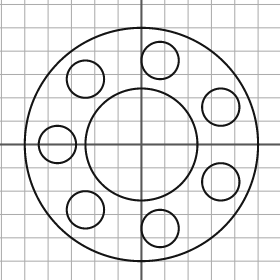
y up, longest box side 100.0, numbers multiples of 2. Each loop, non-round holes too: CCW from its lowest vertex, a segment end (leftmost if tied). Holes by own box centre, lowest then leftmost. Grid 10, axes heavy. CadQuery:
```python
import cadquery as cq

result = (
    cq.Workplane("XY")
    .moveTo(0.0, 0.0)
    .circle(50.0)
    .moveTo(8.0, -36.0)
    .circle(8.0)
    .moveTo(-24.0, -28.0)
    .circle(8.0)
    .moveTo(34.0, -16.0)
    .circle(8.0)
    .moveTo(-36.0, 0.0)
    .circle(8.0)
    .moveTo(0.0, 0.0)
    .circle(24.0)
    .moveTo(34.0, 16.0)
    .circle(8.0)
    .moveTo(-24.0, 28.0)
    .circle(8.0)
    .moveTo(8.0, 36.0)
    .circle(8.0)
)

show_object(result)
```